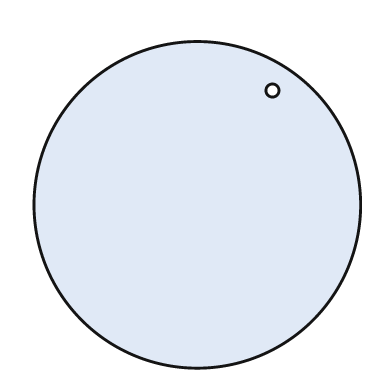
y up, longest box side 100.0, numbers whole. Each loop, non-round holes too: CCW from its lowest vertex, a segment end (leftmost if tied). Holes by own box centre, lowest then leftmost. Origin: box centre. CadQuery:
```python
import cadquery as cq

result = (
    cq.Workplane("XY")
    .moveTo(0.0, 0.0)
    .circle(50.0)
    .moveTo(23.0, 35.0)
    .circle(2.0)
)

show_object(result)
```